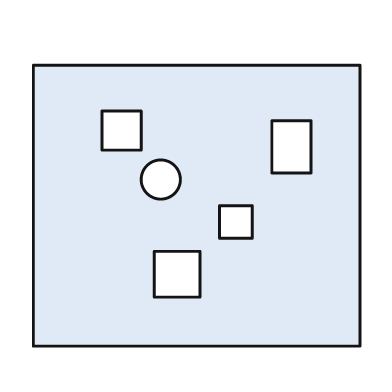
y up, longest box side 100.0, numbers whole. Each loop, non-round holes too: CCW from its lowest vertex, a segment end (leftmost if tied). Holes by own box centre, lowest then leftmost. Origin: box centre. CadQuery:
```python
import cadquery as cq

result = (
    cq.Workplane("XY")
    .moveTo(-50.0, -43.0)
    .lineTo(50.0, -43.0)
    .lineTo(50.0, 43.0)
    .lineTo(-50.0, 43.0)
    .close()
    .moveTo(-13.0, -28.0)
    .lineTo(1.0, -28.0)
    .lineTo(1.0, -14.0)
    .lineTo(-13.0, -14.0)
    .close()
    .moveTo(7.0, -10.0)
    .lineTo(17.0, -10.0)
    .lineTo(17.0, 0.0)
    .lineTo(7.0, 0.0)
    .close()
    .moveTo(-11.0, 8.0)
    .circle(6.0)
    .moveTo(23.0, 10.0)
    .lineTo(35.0, 10.0)
    .lineTo(35.0, 26.0)
    .lineTo(23.0, 26.0)
    .close()
    .moveTo(-29.0, 17.0)
    .lineTo(-17.0, 17.0)
    .lineTo(-17.0, 29.0)
    .lineTo(-29.0, 29.0)
    .close()
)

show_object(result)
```